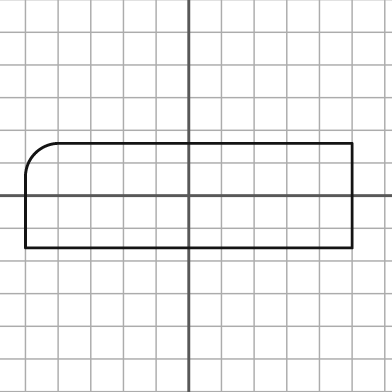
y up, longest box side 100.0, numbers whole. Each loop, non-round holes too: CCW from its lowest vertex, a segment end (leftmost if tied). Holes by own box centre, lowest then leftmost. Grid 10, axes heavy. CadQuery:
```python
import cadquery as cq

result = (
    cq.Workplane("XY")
    .moveTo(-50.0, -16.0)
    .lineTo(50.0, -16.0)
    .lineTo(50.0, 16.0)
    .lineTo(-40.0, 16.0)
    .threePointArc((-47.0, 13.0), (-50.0, 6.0))
    .close()
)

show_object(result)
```